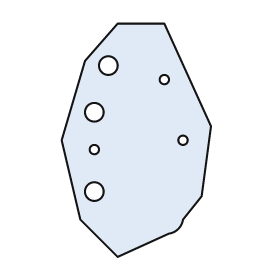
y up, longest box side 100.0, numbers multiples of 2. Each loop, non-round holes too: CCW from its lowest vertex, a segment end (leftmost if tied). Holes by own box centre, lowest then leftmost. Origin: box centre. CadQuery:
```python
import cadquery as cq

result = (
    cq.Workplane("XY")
    .moveTo(-8.0, -50.0)
    .lineTo(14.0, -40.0)
    .threePointArc((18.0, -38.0), (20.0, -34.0))
    .lineTo(28.0, -24.0)
    .lineTo(32.0, 6.0)
    .lineTo(12.0, 50.0)
    .lineTo(-8.0, 50.0)
    .lineTo(-22.0, 34.0)
    .lineTo(-32.0, 0.0)
    .lineTo(-24.0, -34.0)
    .close()
    .moveTo(-18.0, -22.0)
    .circle(4.0)
    .moveTo(-18.0, -4.0)
    .circle(2.0)
    .moveTo(20.0, 0.0)
    .circle(2.0)
    .moveTo(-18.0, 12.0)
    .circle(4.0)
    .moveTo(12.0, 26.0)
    .circle(2.0)
    .moveTo(-12.0, 32.0)
    .circle(4.0)
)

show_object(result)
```